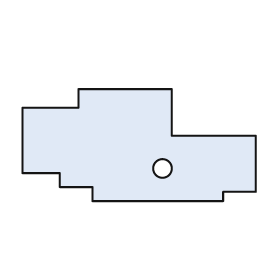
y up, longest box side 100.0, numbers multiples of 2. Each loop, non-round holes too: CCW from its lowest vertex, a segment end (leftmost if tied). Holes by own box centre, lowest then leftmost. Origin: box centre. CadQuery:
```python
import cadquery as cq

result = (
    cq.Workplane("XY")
    .moveTo(-20.0, -24.0)
    .lineTo(36.0, -24.0)
    .lineTo(36.0, -20.0)
    .lineTo(50.0, -20.0)
    .lineTo(50.0, 4.0)
    .lineTo(14.0, 4.0)
    .lineTo(14.0, 24.0)
    .lineTo(-26.0, 24.0)
    .lineTo(-26.0, 16.0)
    .lineTo(-50.0, 16.0)
    .lineTo(-50.0, -12.0)
    .lineTo(-34.0, -12.0)
    .lineTo(-34.0, -18.0)
    .lineTo(-20.0, -18.0)
    .close()
    .moveTo(10.0, -10.0)
    .circle(4.0)
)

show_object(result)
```